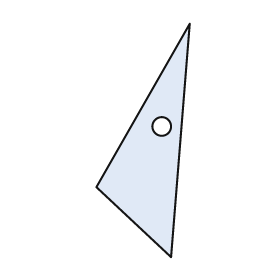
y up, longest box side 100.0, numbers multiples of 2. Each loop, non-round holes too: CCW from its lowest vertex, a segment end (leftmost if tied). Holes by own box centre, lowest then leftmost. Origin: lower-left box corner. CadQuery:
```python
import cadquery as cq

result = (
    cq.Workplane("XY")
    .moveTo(32.0, 0.0)
    .lineTo(40.0, 100.0)
    .lineTo(0.0, 30.0)
    .close()
    .moveTo(28.0, 56.0)
    .circle(4.0)
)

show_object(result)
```